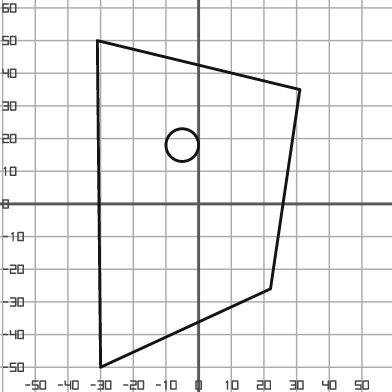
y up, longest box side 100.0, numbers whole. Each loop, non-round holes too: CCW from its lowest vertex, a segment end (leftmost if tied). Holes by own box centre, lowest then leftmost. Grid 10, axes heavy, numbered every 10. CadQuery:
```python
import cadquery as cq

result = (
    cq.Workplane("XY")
    .moveTo(-30.0, -50.0)
    .lineTo(22.0, -26.0)
    .lineTo(31.0, 35.0)
    .lineTo(-31.0, 50.0)
    .close()
    .moveTo(-5.0, 18.0)
    .circle(5.0)
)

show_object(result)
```